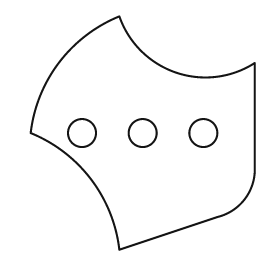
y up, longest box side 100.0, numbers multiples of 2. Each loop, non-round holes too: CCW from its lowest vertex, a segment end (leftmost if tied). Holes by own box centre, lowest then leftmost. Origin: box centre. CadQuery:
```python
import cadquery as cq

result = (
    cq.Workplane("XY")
    .moveTo(-10.0, -50.0)
    .lineTo(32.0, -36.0)
    .threePointArc((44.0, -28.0), (48.0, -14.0))
    .lineTo(48.0, 30.0)
    .threePointArc((14.0, 26.0), (-10.0, 50.0))
    .threePointArc((-36.0, 30.0), (-48.0, 0.0))
    .threePointArc((-22.0, -20.0), (-10.0, -50.0))
    .close()
    .moveTo(-26.0, 0.0)
    .circle(6.0)
    .moveTo(0.0, 0.0)
    .circle(6.0)
    .moveTo(26.0, 0.0)
    .circle(6.0)
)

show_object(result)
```